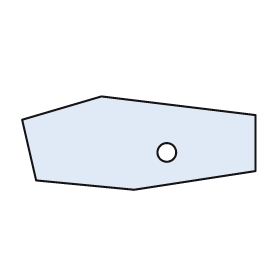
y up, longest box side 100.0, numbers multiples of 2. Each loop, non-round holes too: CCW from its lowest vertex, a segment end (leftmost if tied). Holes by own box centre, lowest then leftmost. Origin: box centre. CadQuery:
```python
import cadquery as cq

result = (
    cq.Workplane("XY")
    .moveTo(-2.0, -20.0)
    .lineTo(50.0, -12.0)
    .lineTo(50.0, 12.0)
    .lineTo(-16.0, 20.0)
    .lineTo(-50.0, 10.0)
    .lineTo(-44.0, -16.0)
    .close()
    .moveTo(12.0, -4.0)
    .circle(4.0)
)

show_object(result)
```